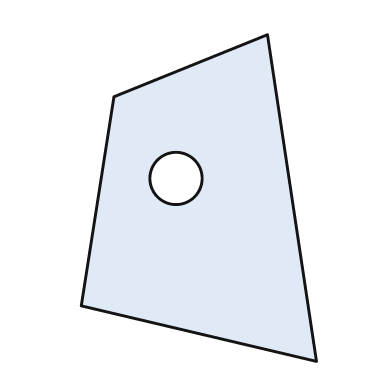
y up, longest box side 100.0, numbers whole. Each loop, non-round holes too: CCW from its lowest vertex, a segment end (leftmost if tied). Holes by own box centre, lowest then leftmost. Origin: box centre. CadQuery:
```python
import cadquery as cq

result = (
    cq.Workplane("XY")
    .moveTo(36.0, -50.0)
    .lineTo(21.0, 50.0)
    .lineTo(-26.0, 31.0)
    .lineTo(-36.0, -33.0)
    .close()
    .moveTo(-7.0, 6.0)
    .circle(8.0)
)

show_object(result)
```